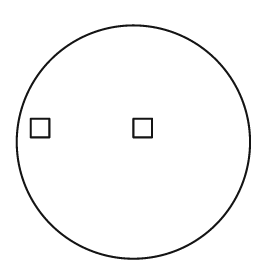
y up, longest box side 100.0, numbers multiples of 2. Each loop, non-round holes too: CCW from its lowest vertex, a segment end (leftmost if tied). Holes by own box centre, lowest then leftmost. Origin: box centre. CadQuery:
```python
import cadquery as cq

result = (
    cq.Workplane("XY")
    .moveTo(0.0, 0.0)
    .circle(50.0)
    .moveTo(-44.0, 2.0)
    .lineTo(-36.0, 2.0)
    .lineTo(-36.0, 10.0)
    .lineTo(-44.0, 10.0)
    .close()
    .moveTo(0.0, 2.0)
    .lineTo(8.0, 2.0)
    .lineTo(8.0, 10.0)
    .lineTo(0.0, 10.0)
    .close()
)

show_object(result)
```